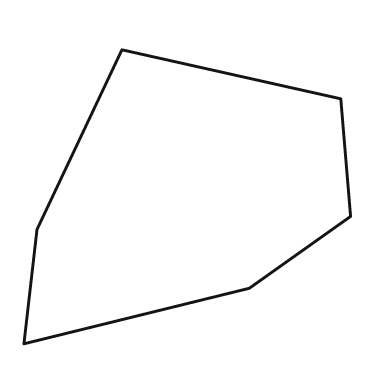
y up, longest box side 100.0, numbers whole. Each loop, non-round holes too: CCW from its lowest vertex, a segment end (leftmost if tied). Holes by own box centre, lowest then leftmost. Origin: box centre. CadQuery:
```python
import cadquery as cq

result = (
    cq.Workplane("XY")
    .moveTo(-50.0, -45.0)
    .lineTo(19.0, -28.0)
    .lineTo(50.0, -6.0)
    .lineTo(47.0, 30.0)
    .lineTo(-20.0, 45.0)
    .lineTo(-46.0, -10.0)
    .close()
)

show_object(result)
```